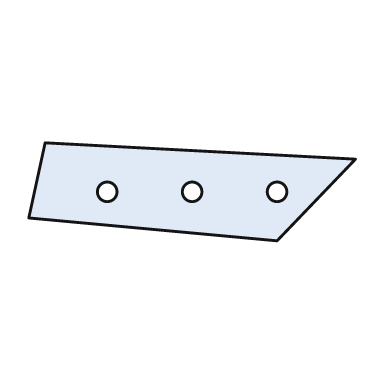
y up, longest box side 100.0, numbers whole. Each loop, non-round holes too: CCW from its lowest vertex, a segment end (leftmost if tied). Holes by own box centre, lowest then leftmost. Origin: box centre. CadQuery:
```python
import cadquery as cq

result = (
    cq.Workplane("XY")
    .moveTo(26.0, -15.0)
    .lineTo(50.0, 10.0)
    .lineTo(-45.0, 15.0)
    .lineTo(-50.0, -8.0)
    .close()
    .moveTo(-26.0, 0.0)
    .circle(3.0)
    .moveTo(0.0, 0.0)
    .circle(3.0)
    .moveTo(26.0, 0.0)
    .circle(3.0)
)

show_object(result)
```